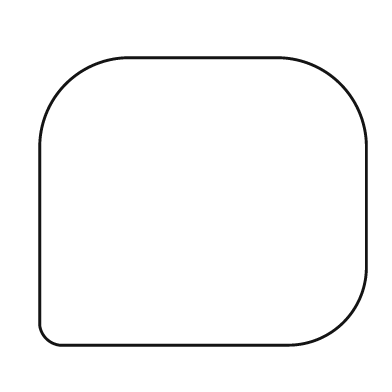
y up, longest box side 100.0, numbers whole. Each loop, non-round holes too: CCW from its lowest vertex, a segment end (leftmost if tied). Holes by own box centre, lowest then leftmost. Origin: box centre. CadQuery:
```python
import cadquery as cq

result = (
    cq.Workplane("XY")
    .moveTo(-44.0, -44.0)
    .lineTo(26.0, -44.0)
    .threePointArc((43.0, -37.0), (50.0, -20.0))
    .lineTo(50.0, 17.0)
    .threePointArc((42.0, 36.0), (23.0, 44.0))
    .lineTo(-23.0, 44.0)
    .threePointArc((-42.0, 36.0), (-50.0, 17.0))
    .lineTo(-50.0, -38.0)
    .threePointArc((-48.0, -42.0), (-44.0, -44.0))
    .close()
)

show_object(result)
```